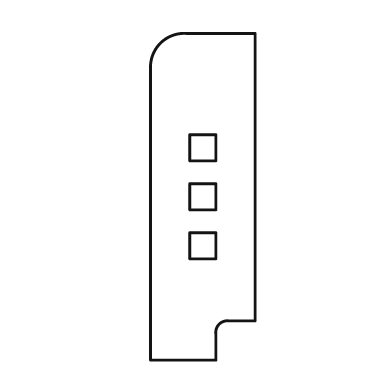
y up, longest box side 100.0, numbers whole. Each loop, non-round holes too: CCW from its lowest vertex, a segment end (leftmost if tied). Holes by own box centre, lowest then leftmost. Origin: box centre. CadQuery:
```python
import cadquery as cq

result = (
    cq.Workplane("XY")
    .moveTo(-16.0, -50.0)
    .lineTo(4.0, -50.0)
    .lineTo(4.0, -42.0)
    .threePointArc((5.0, -39.0), (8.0, -38.0))
    .lineTo(16.0, -38.0)
    .lineTo(16.0, 50.0)
    .lineTo(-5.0, 50.0)
    .threePointArc((-13.0, 47.0), (-16.0, 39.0))
    .close()
    .moveTo(-4.0, -19.0)
    .lineTo(4.0, -19.0)
    .lineTo(4.0, -11.0)
    .lineTo(-4.0, -11.0)
    .close()
    .moveTo(-4.0, -4.0)
    .lineTo(4.0, -4.0)
    .lineTo(4.0, 4.0)
    .lineTo(-4.0, 4.0)
    .close()
    .moveTo(-4.0, 11.0)
    .lineTo(4.0, 11.0)
    .lineTo(4.0, 19.0)
    .lineTo(-4.0, 19.0)
    .close()
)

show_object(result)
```